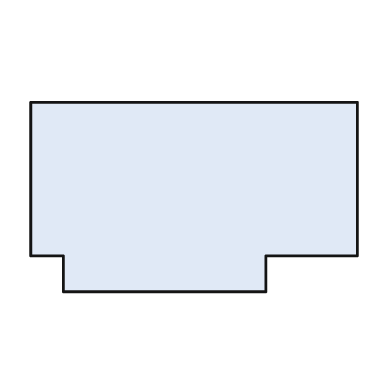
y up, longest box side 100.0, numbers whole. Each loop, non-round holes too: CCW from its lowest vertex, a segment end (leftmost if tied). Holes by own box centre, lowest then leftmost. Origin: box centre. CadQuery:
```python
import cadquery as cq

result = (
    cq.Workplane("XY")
    .moveTo(-40.0, -29.0)
    .lineTo(22.0, -29.0)
    .lineTo(22.0, -18.0)
    .lineTo(50.0, -18.0)
    .lineTo(50.0, 29.0)
    .lineTo(-50.0, 29.0)
    .lineTo(-50.0, -18.0)
    .lineTo(-40.0, -18.0)
    .close()
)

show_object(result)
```